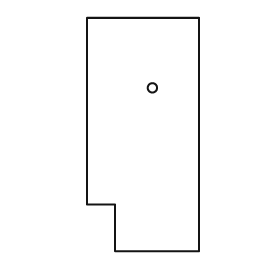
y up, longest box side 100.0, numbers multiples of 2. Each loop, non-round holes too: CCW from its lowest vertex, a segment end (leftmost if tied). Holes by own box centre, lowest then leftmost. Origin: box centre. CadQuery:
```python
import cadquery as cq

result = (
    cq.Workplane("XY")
    .moveTo(-12.0, -50.0)
    .lineTo(24.0, -50.0)
    .lineTo(24.0, 50.0)
    .lineTo(-24.0, 50.0)
    .lineTo(-24.0, -30.0)
    .lineTo(-12.0, -30.0)
    .close()
    .moveTo(4.0, 20.0)
    .circle(2.0)
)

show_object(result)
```